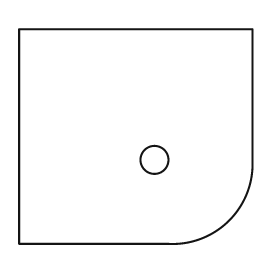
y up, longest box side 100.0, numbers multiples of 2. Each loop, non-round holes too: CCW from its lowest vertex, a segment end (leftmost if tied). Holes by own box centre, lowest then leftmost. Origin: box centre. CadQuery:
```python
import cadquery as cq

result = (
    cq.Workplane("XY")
    .moveTo(-50.0, -46.0)
    .lineTo(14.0, -46.0)
    .threePointArc((40.0, -36.0), (50.0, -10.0))
    .lineTo(50.0, 46.0)
    .lineTo(-50.0, 46.0)
    .close()
    .moveTo(8.0, -10.0)
    .circle(6.0)
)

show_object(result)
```